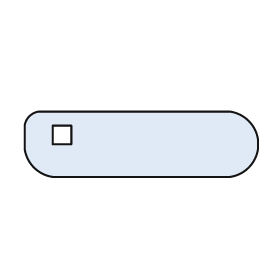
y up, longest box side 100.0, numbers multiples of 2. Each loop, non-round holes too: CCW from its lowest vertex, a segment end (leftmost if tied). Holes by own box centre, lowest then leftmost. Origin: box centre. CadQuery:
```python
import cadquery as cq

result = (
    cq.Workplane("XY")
    .moveTo(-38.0, -14.0)
    .lineTo(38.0, -14.0)
    .threePointArc((46.0, -10.0), (50.0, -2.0))
    .lineTo(50.0, 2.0)
    .threePointArc((46.0, 10.0), (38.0, 14.0))
    .lineTo(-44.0, 14.0)
    .threePointArc((-48.0, 12.0), (-50.0, 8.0))
    .lineTo(-50.0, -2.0)
    .threePointArc((-46.0, -10.0), (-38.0, -14.0))
    .close()
    .moveTo(-38.0, 0.0)
    .lineTo(-30.0, 0.0)
    .lineTo(-30.0, 8.0)
    .lineTo(-38.0, 8.0)
    .close()
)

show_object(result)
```